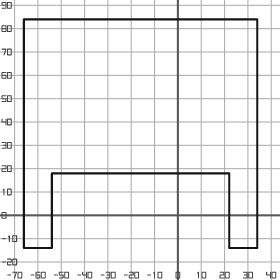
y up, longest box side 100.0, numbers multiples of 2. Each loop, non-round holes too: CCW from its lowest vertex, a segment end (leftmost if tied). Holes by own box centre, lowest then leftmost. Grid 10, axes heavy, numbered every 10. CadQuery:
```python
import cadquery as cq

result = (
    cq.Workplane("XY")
    .moveTo(-66.0, -14.0)
    .lineTo(-54.0, -14.0)
    .lineTo(-54.0, 18.0)
    .lineTo(22.0, 18.0)
    .lineTo(22.0, -14.0)
    .lineTo(34.0, -14.0)
    .lineTo(34.0, 84.0)
    .lineTo(-66.0, 84.0)
    .close()
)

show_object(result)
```